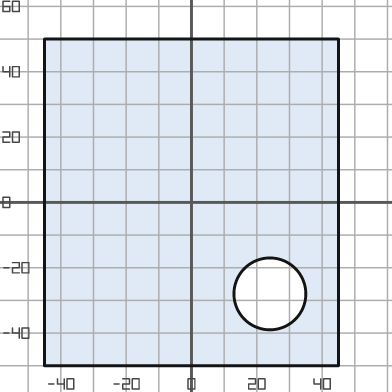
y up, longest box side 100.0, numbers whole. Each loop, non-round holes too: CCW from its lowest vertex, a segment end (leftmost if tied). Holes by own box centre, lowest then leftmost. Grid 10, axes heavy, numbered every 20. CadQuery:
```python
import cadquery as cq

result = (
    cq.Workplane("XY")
    .moveTo(-45.0, -50.0)
    .lineTo(45.0, -50.0)
    .lineTo(45.0, 50.0)
    .lineTo(-45.0, 50.0)
    .close()
    .moveTo(24.0, -28.0)
    .circle(11.0)
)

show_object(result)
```